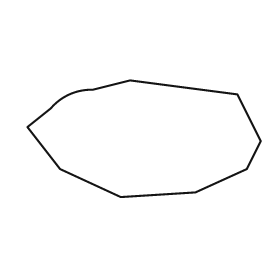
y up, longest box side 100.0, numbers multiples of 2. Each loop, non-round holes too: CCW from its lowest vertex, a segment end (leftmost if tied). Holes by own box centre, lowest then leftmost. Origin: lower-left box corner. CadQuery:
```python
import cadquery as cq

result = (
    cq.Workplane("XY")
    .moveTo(40.0, 0.0)
    .lineTo(72.0, 2.0)
    .lineTo(94.0, 12.0)
    .lineTo(100.0, 24.0)
    .lineTo(90.0, 44.0)
    .lineTo(44.0, 50.0)
    .lineTo(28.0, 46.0)
    .threePointArc((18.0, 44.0), (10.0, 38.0))
    .lineTo(0.0, 30.0)
    .lineTo(14.0, 12.0)
    .close()
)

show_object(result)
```